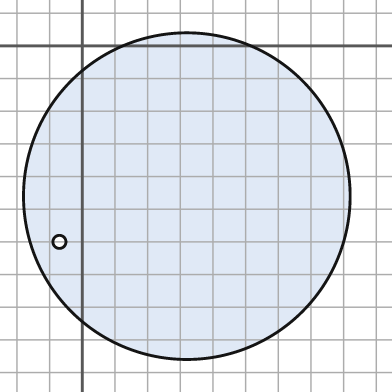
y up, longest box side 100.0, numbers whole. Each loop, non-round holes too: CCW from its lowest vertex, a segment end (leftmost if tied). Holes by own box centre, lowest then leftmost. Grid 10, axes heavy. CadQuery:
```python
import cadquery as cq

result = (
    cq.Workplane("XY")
    .moveTo(32.0, -46.0)
    .circle(50.0)
    .moveTo(-7.0, -60.0)
    .circle(2.0)
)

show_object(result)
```